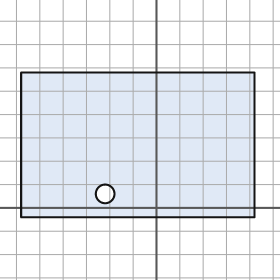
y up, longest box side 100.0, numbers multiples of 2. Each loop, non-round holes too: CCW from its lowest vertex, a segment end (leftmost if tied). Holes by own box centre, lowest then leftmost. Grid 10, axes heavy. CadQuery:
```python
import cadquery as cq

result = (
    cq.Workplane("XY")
    .moveTo(-58.0, -4.0)
    .lineTo(42.0, -4.0)
    .lineTo(42.0, 58.0)
    .lineTo(-58.0, 58.0)
    .close()
    .moveTo(-22.0, 6.0)
    .circle(4.0)
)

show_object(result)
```